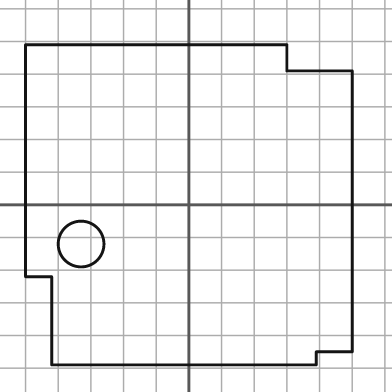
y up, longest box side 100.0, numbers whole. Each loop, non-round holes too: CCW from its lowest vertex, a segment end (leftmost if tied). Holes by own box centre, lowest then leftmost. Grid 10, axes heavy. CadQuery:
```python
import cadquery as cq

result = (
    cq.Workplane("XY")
    .moveTo(-42.0, -49.0)
    .lineTo(39.0, -49.0)
    .lineTo(39.0, -45.0)
    .lineTo(50.0, -45.0)
    .lineTo(50.0, 41.0)
    .lineTo(30.0, 41.0)
    .lineTo(30.0, 49.0)
    .lineTo(-50.0, 49.0)
    .lineTo(-50.0, -22.0)
    .lineTo(-42.0, -22.0)
    .close()
    .moveTo(-33.0, -12.0)
    .circle(7.0)
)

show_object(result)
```